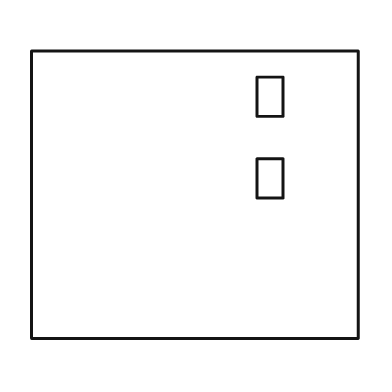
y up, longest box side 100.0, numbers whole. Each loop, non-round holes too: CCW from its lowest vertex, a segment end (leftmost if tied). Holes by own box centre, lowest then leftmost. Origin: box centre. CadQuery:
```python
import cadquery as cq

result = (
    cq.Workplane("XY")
    .moveTo(-50.0, -44.0)
    .lineTo(50.0, -44.0)
    .lineTo(50.0, 44.0)
    .lineTo(-50.0, 44.0)
    .close()
    .moveTo(19.0, -1.0)
    .lineTo(27.0, -1.0)
    .lineTo(27.0, 11.0)
    .lineTo(19.0, 11.0)
    .close()
    .moveTo(19.0, 24.0)
    .lineTo(27.0, 24.0)
    .lineTo(27.0, 36.0)
    .lineTo(19.0, 36.0)
    .close()
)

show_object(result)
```